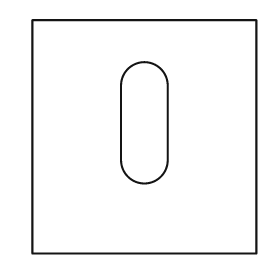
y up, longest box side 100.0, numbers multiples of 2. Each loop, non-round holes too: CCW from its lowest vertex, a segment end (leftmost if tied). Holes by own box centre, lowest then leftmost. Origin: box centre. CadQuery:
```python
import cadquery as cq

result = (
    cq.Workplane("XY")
    .moveTo(-48.0, -50.0)
    .lineTo(48.0, -50.0)
    .lineTo(48.0, 50.0)
    .lineTo(-48.0, 50.0)
    .close()
    .moveTo(-10.0, -10.0)
    .threePointArc((0.0, -20.0), (10.0, -10.0))
    .lineTo(10.0, 22.0)
    .threePointArc((0.0, 32.0), (-10.0, 22.0))
    .close()
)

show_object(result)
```